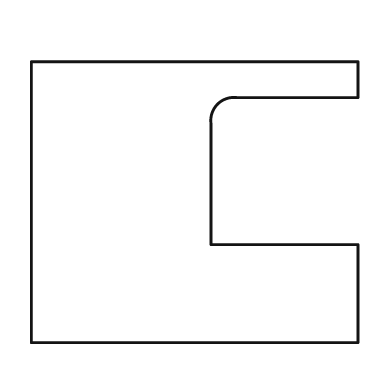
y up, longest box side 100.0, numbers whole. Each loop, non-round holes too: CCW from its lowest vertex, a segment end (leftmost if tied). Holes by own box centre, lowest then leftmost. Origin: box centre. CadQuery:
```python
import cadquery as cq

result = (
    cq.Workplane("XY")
    .moveTo(-50.0, -43.0)
    .lineTo(50.0, -43.0)
    .lineTo(50.0, -13.0)
    .lineTo(5.0, -13.0)
    .lineTo(5.0, 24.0)
    .threePointArc((7.0, 30.0), (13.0, 32.0))
    .lineTo(50.0, 32.0)
    .lineTo(50.0, 43.0)
    .lineTo(-50.0, 43.0)
    .close()
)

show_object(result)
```